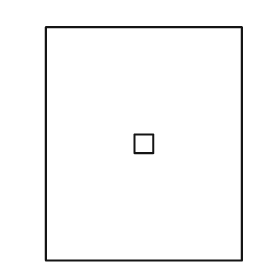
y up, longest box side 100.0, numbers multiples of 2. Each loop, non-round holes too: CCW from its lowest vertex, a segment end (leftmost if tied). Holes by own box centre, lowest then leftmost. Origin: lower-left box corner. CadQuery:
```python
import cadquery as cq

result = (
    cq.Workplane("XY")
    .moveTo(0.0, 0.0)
    .lineTo(84.0, 0.0)
    .lineTo(84.0, 100.0)
    .lineTo(0.0, 100.0)
    .close()
    .moveTo(38.0, 46.0)
    .lineTo(46.0, 46.0)
    .lineTo(46.0, 54.0)
    .lineTo(38.0, 54.0)
    .close()
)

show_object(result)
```